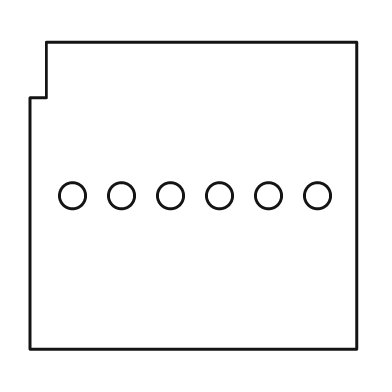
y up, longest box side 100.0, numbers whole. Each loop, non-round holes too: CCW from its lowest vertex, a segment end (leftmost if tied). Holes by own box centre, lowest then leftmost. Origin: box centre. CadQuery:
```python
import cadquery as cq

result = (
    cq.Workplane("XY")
    .moveTo(-50.0, -47.0)
    .lineTo(50.0, -47.0)
    .lineTo(50.0, 47.0)
    .lineTo(-45.0, 47.0)
    .lineTo(-45.0, 30.0)
    .lineTo(-50.0, 30.0)
    .close()
    .moveTo(-37.0, 0.0)
    .circle(4.0)
    .moveTo(-22.0, 0.0)
    .circle(4.0)
    .moveTo(-7.0, 0.0)
    .circle(4.0)
    .moveTo(8.0, 0.0)
    .circle(4.0)
    .moveTo(23.0, 0.0)
    .circle(4.0)
    .moveTo(38.0, 0.0)
    .circle(4.0)
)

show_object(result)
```